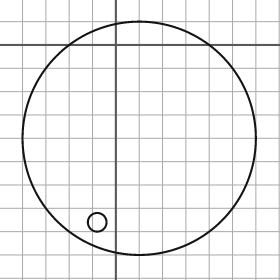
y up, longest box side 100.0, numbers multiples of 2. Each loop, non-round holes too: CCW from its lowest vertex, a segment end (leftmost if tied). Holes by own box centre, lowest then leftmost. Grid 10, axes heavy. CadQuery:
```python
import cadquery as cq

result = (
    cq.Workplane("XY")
    .moveTo(10.0, -40.0)
    .circle(50.0)
    .moveTo(-8.0, -76.0)
    .circle(4.0)
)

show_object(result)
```